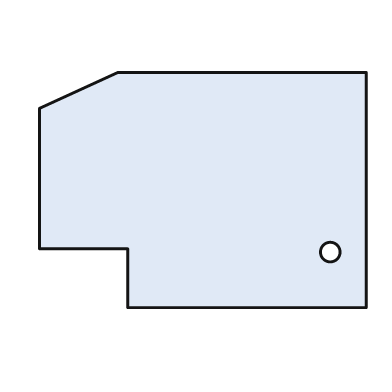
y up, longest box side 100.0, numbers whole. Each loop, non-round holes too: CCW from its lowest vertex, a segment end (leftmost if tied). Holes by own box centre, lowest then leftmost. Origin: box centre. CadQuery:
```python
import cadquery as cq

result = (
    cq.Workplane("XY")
    .moveTo(-23.0, -36.0)
    .lineTo(50.0, -36.0)
    .lineTo(50.0, 36.0)
    .lineTo(-26.0, 36.0)
    .lineTo(-50.0, 25.0)
    .lineTo(-50.0, -18.0)
    .lineTo(-23.0, -18.0)
    .close()
    .moveTo(39.0, -19.0)
    .circle(3.0)
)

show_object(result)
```